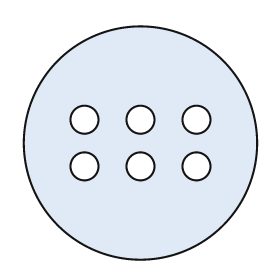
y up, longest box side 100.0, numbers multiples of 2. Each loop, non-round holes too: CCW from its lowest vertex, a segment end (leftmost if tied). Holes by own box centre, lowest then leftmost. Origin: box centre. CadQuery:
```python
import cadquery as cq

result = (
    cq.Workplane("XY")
    .moveTo(0.0, 0.0)
    .circle(50.0)
    .moveTo(-24.0, -10.0)
    .circle(6.0)
    .moveTo(0.0, -10.0)
    .circle(6.0)
    .moveTo(24.0, -10.0)
    .circle(6.0)
    .moveTo(-24.0, 10.0)
    .circle(6.0)
    .moveTo(0.0, 10.0)
    .circle(6.0)
    .moveTo(24.0, 10.0)
    .circle(6.0)
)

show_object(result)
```